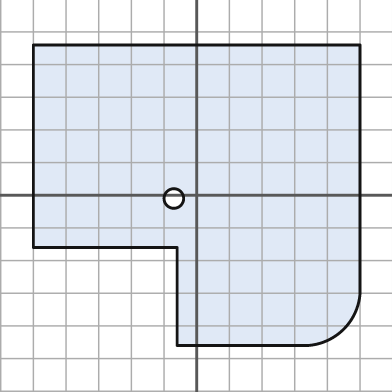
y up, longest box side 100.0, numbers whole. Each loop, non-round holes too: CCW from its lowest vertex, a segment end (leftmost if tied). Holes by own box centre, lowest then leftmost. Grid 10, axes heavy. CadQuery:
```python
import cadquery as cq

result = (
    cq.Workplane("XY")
    .moveTo(-6.0, -46.0)
    .lineTo(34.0, -46.0)
    .threePointArc((45.0, -41.0), (50.0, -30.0))
    .lineTo(50.0, 46.0)
    .lineTo(-50.0, 46.0)
    .lineTo(-50.0, -16.0)
    .lineTo(-6.0, -16.0)
    .close()
    .moveTo(-7.0, -1.0)
    .circle(3.0)
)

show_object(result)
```